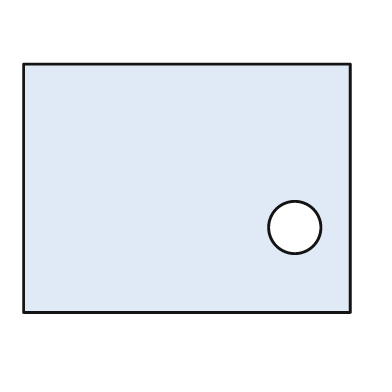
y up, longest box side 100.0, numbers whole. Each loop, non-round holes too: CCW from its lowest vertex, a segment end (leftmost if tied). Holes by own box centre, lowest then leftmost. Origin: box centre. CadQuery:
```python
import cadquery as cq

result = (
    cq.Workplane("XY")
    .moveTo(-50.0, -38.0)
    .lineTo(50.0, -38.0)
    .lineTo(50.0, 38.0)
    .lineTo(-50.0, 38.0)
    .close()
    .moveTo(33.0, -12.0)
    .circle(8.0)
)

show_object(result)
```